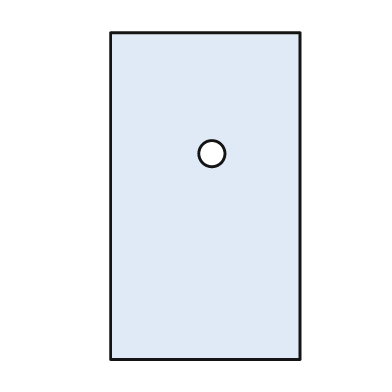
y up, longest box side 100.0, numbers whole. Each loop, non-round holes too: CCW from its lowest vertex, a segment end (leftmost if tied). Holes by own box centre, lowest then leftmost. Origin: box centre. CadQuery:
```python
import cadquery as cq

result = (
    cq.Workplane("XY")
    .moveTo(-29.0, -50.0)
    .lineTo(29.0, -50.0)
    .lineTo(29.0, 50.0)
    .lineTo(-29.0, 50.0)
    .close()
    .moveTo(2.0, 13.0)
    .circle(4.0)
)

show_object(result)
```